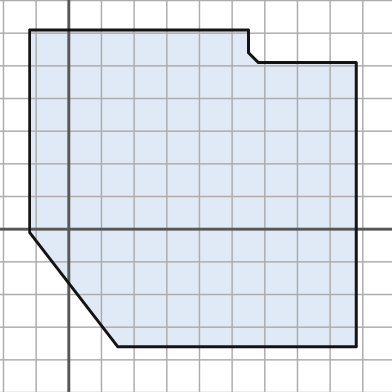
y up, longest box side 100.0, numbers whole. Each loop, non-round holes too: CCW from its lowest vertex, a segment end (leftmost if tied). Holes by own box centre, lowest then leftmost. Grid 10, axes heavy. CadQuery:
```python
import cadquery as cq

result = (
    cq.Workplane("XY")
    .moveTo(15.0, -36.0)
    .lineTo(88.0, -36.0)
    .lineTo(88.0, 51.0)
    .lineTo(58.0, 51.0)
    .lineTo(55.0, 54.0)
    .lineTo(55.0, 61.0)
    .lineTo(-12.0, 61.0)
    .lineTo(-12.0, -1.0)
    .close()
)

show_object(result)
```